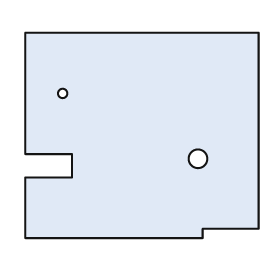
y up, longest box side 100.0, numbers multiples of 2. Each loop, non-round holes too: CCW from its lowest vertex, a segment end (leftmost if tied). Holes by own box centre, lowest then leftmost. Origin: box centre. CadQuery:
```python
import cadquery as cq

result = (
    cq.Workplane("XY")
    .moveTo(-50.0, -44.0)
    .lineTo(26.0, -44.0)
    .lineTo(26.0, -40.0)
    .lineTo(50.0, -40.0)
    .lineTo(50.0, 44.0)
    .lineTo(-50.0, 44.0)
    .lineTo(-50.0, -8.0)
    .lineTo(-30.0, -8.0)
    .lineTo(-30.0, -18.0)
    .lineTo(-50.0, -18.0)
    .close()
    .moveTo(24.0, -10.0)
    .circle(4.0)
    .moveTo(-34.0, 18.0)
    .circle(2.0)
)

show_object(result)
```